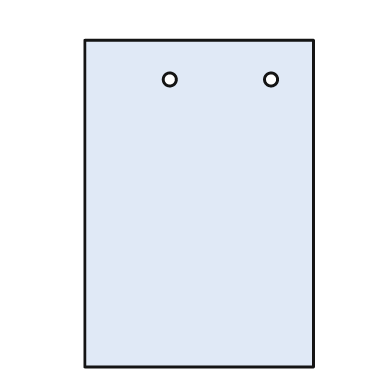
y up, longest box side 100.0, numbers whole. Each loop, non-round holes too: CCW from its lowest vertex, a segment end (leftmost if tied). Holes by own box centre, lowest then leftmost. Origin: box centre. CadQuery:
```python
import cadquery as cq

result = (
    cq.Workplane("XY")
    .moveTo(-35.0, -50.0)
    .lineTo(35.0, -50.0)
    .lineTo(35.0, 50.0)
    .lineTo(-35.0, 50.0)
    .close()
    .moveTo(-9.0, 38.0)
    .circle(2.0)
    .moveTo(22.0, 38.0)
    .circle(2.0)
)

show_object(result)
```